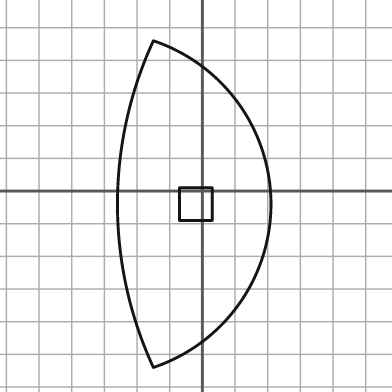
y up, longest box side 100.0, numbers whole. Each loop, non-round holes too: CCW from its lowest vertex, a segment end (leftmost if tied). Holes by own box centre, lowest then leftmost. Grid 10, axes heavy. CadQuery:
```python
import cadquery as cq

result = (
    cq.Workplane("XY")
    .moveTo(-15.0, -54.0)
    .threePointArc((21.0, -4.0), (-15.0, 46.0))
    .threePointArc((-26.0, -4.0), (-15.0, -54.0))
    .close()
    .moveTo(-7.0, -9.0)
    .lineTo(3.0, -9.0)
    .lineTo(3.0, 1.0)
    .lineTo(-7.0, 1.0)
    .close()
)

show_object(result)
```